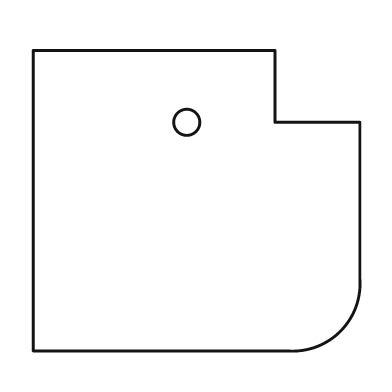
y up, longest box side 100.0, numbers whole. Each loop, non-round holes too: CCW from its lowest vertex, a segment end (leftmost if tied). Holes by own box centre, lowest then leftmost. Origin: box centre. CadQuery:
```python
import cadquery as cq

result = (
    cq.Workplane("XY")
    .moveTo(-50.0, -46.0)
    .lineTo(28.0, -46.0)
    .threePointArc((44.0, -40.0), (50.0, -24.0))
    .lineTo(50.0, 24.0)
    .lineTo(24.0, 24.0)
    .lineTo(24.0, 46.0)
    .lineTo(-50.0, 46.0)
    .close()
    .moveTo(-3.0, 24.0)
    .circle(4.0)
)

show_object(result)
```